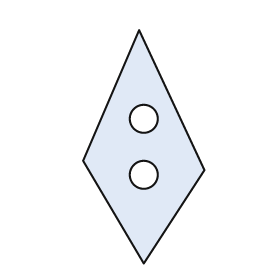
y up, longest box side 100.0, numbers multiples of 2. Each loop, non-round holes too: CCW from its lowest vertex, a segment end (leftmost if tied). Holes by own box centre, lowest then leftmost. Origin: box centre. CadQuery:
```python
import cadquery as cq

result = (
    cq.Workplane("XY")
    .moveTo(0.0, -50.0)
    .lineTo(26.0, -10.0)
    .lineTo(-2.0, 50.0)
    .lineTo(-26.0, -6.0)
    .close()
    .moveTo(0.0, -12.0)
    .circle(6.0)
    .moveTo(0.0, 12.0)
    .circle(6.0)
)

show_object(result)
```